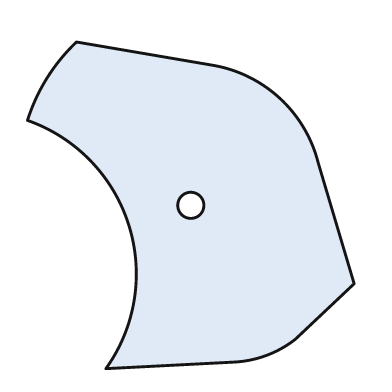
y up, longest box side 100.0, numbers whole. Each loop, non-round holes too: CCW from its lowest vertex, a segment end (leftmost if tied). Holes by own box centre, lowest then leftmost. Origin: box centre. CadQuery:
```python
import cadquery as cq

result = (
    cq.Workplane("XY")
    .moveTo(-26.0, -50.0)
    .lineTo(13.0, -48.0)
    .threePointArc((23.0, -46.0), (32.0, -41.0))
    .lineTo(50.0, -24.0)
    .lineTo(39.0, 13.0)
    .threePointArc((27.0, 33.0), (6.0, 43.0))
    .lineTo(-35.0, 50.0)
    .threePointArc((-44.0, 39.0), (-50.0, 26.0))
    .threePointArc((-19.0, -6.0), (-26.0, -50.0))
    .close()
    .moveTo(0.0, 0.0)
    .circle(4.0)
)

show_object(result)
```